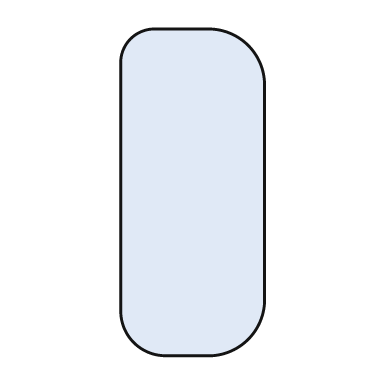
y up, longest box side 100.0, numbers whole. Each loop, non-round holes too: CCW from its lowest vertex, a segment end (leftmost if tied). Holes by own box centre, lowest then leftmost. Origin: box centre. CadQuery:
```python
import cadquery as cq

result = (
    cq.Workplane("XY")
    .moveTo(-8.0, -50.0)
    .lineTo(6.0, -50.0)
    .threePointArc((17.0, -45.0), (22.0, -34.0))
    .lineTo(22.0, 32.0)
    .threePointArc((17.0, 45.0), (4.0, 50.0))
    .lineTo(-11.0, 50.0)
    .threePointArc((-19.0, 47.0), (-22.0, 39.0))
    .lineTo(-22.0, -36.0)
    .threePointArc((-18.0, -46.0), (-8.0, -50.0))
    .close()
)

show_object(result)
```